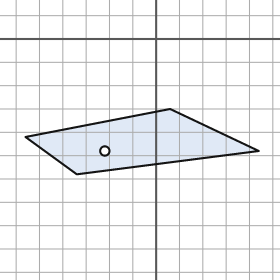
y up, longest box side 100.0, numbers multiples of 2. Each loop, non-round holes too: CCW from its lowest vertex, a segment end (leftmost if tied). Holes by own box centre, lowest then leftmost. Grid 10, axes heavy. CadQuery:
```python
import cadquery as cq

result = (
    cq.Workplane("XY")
    .moveTo(-34.0, -58.0)
    .lineTo(44.0, -48.0)
    .lineTo(6.0, -30.0)
    .lineTo(-56.0, -42.0)
    .close()
    .moveTo(-22.0, -48.0)
    .circle(2.0)
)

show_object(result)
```